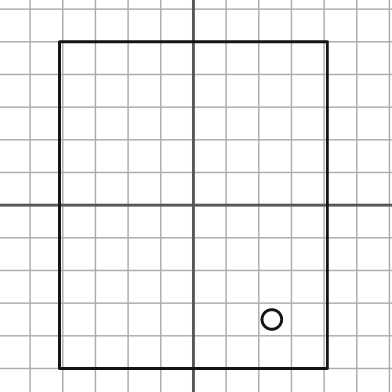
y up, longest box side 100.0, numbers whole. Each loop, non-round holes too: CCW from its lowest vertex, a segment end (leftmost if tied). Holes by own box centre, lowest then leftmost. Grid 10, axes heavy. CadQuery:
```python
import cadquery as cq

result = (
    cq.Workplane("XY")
    .moveTo(-41.0, -50.0)
    .lineTo(41.0, -50.0)
    .lineTo(41.0, 50.0)
    .lineTo(-41.0, 50.0)
    .close()
    .moveTo(24.0, -35.0)
    .circle(3.0)
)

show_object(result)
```